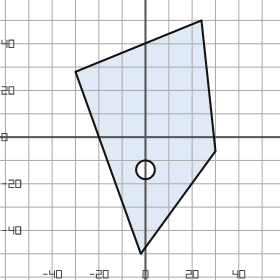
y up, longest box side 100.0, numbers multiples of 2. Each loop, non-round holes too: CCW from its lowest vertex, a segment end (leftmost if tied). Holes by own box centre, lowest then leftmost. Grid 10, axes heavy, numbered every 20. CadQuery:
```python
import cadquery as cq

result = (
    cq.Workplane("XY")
    .moveTo(-2.0, -50.0)
    .lineTo(30.0, -6.0)
    .lineTo(24.0, 50.0)
    .lineTo(-30.0, 28.0)
    .close()
    .moveTo(0.0, -14.0)
    .circle(4.0)
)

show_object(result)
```